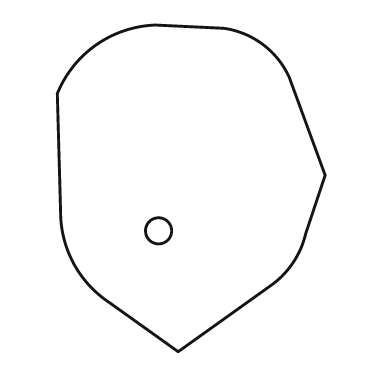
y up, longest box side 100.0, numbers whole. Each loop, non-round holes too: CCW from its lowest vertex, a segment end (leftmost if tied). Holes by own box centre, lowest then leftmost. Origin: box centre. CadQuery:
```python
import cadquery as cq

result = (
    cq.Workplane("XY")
    .moveTo(-4.0, -50.0)
    .lineTo(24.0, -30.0)
    .threePointArc((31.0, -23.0), (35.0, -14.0))
    .lineTo(41.0, 4.0)
    .lineTo(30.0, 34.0)
    .threePointArc((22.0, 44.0), (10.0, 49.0))
    .lineTo(-11.0, 50.0)
    .threePointArc((-29.0, 44.0), (-41.0, 29.0))
    .lineTo(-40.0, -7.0)
    .threePointArc((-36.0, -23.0), (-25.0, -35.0))
    .close()
    .moveTo(-10.0, -13.0)
    .circle(4.0)
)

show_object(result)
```